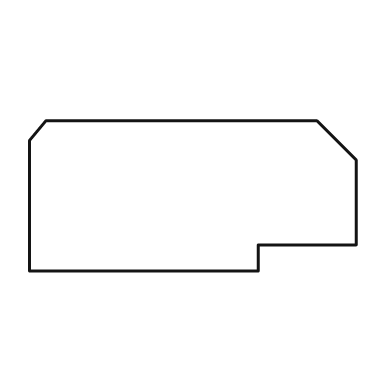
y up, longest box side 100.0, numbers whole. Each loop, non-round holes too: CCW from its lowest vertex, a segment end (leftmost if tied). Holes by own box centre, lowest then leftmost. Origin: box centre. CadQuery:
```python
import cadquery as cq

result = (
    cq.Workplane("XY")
    .moveTo(-50.0, -23.0)
    .lineTo(20.0, -23.0)
    .lineTo(20.0, -15.0)
    .lineTo(50.0, -15.0)
    .lineTo(50.0, 11.0)
    .lineTo(38.0, 23.0)
    .lineTo(-45.0, 23.0)
    .lineTo(-50.0, 17.0)
    .close()
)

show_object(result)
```